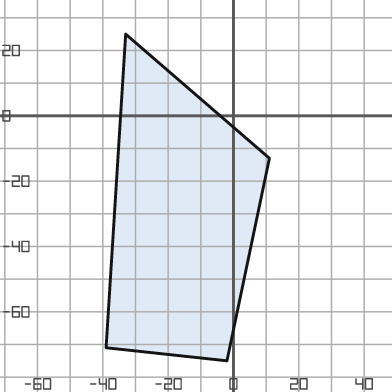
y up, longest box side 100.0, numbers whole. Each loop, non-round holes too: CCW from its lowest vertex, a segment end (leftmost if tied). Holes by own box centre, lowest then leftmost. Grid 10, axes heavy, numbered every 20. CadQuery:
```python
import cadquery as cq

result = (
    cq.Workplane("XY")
    .moveTo(-2.0, -75.0)
    .lineTo(11.0, -13.0)
    .lineTo(-33.0, 25.0)
    .lineTo(-39.0, -71.0)
    .close()
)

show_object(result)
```